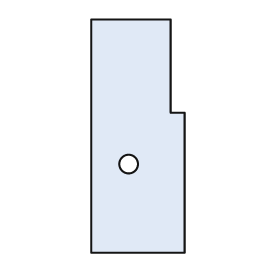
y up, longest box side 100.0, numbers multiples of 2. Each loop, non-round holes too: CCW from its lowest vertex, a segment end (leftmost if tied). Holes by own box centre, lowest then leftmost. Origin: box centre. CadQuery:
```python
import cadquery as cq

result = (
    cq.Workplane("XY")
    .moveTo(-20.0, -50.0)
    .lineTo(20.0, -50.0)
    .lineTo(20.0, 10.0)
    .lineTo(14.0, 10.0)
    .lineTo(14.0, 50.0)
    .lineTo(-20.0, 50.0)
    .close()
    .moveTo(-4.0, -12.0)
    .circle(4.0)
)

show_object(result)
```